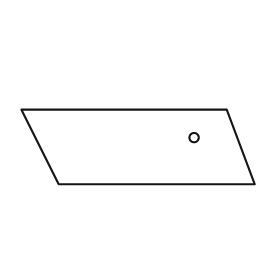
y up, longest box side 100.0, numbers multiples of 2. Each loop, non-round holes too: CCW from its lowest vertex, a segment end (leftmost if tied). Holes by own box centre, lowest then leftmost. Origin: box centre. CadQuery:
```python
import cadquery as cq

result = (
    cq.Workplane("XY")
    .moveTo(-34.0, -16.0)
    .lineTo(50.0, -16.0)
    .lineTo(38.0, 16.0)
    .lineTo(-50.0, 16.0)
    .close()
    .moveTo(24.0, 4.0)
    .circle(2.0)
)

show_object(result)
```